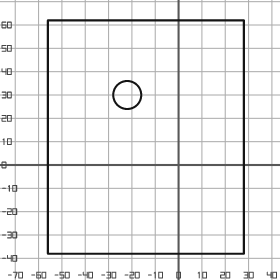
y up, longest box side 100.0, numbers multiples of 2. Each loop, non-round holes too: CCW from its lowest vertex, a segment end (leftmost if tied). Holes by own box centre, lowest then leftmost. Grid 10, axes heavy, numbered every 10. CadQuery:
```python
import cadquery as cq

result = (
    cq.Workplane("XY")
    .moveTo(-56.0, -38.0)
    .lineTo(28.0, -38.0)
    .lineTo(28.0, 62.0)
    .lineTo(-56.0, 62.0)
    .close()
    .moveTo(-22.0, 30.0)
    .circle(6.0)
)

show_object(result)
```